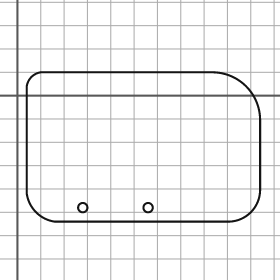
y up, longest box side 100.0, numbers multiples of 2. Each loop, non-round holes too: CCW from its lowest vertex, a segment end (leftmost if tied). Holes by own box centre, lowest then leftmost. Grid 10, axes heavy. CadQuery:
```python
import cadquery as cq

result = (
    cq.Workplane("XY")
    .moveTo(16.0, -54.0)
    .lineTo(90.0, -54.0)
    .threePointArc((100.0, -50.0), (104.0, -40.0))
    .lineTo(104.0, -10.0)
    .threePointArc((98.0, 4.0), (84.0, 10.0))
    .lineTo(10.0, 10.0)
    .threePointArc((6.0, 8.0), (4.0, 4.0))
    .lineTo(4.0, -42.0)
    .threePointArc((8.0, -50.0), (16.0, -54.0))
    .close()
    .moveTo(28.0, -48.0)
    .circle(2.0)
    .moveTo(56.0, -48.0)
    .circle(2.0)
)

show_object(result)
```